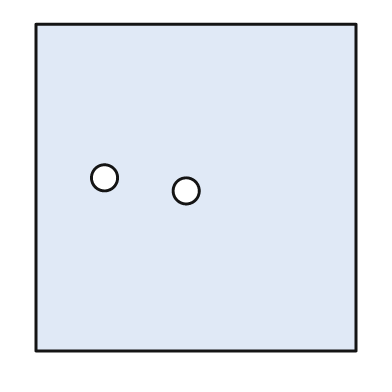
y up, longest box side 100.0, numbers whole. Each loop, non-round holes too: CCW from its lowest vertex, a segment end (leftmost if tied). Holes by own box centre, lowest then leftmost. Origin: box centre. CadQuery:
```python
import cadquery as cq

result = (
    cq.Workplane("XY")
    .moveTo(-49.0, -50.0)
    .lineTo(49.0, -50.0)
    .lineTo(49.0, 50.0)
    .lineTo(-49.0, 50.0)
    .close()
    .moveTo(-3.0, -1.0)
    .circle(4.0)
    .moveTo(-28.0, 3.0)
    .circle(4.0)
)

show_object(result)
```